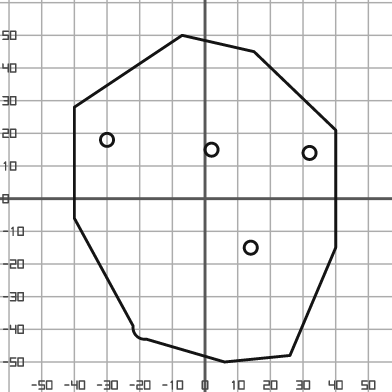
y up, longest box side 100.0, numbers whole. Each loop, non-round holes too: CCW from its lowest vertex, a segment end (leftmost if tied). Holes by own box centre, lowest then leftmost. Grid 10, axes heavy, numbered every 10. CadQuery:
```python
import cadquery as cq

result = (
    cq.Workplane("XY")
    .moveTo(6.0, -50.0)
    .lineTo(26.0, -48.0)
    .lineTo(40.0, -15.0)
    .lineTo(40.0, 21.0)
    .lineTo(15.0, 45.0)
    .lineTo(-7.0, 50.0)
    .lineTo(-40.0, 28.0)
    .lineTo(-40.0, -6.0)
    .lineTo(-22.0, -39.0)
    .threePointArc((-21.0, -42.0), (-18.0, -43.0))
    .close()
    .moveTo(14.0, -15.0)
    .circle(2.0)
    .moveTo(32.0, 14.0)
    .circle(2.0)
    .moveTo(2.0, 15.0)
    .circle(2.0)
    .moveTo(-30.0, 18.0)
    .circle(2.0)
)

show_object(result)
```